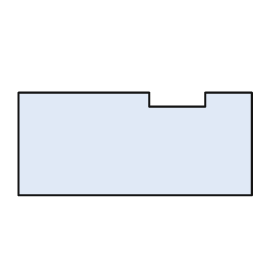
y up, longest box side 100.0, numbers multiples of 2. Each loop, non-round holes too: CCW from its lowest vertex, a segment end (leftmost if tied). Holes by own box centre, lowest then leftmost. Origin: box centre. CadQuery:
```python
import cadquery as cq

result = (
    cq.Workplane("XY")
    .moveTo(-50.0, -22.0)
    .lineTo(50.0, -22.0)
    .lineTo(50.0, 22.0)
    .lineTo(30.0, 22.0)
    .lineTo(30.0, 16.0)
    .lineTo(6.0, 16.0)
    .lineTo(6.0, 22.0)
    .lineTo(-50.0, 22.0)
    .close()
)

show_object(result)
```